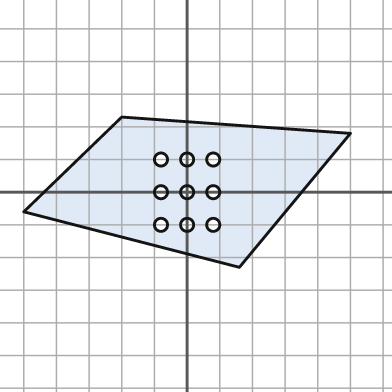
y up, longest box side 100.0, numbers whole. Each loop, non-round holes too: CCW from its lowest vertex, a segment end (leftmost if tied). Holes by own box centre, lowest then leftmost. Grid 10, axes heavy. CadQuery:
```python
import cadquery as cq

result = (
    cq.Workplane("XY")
    .moveTo(16.0, -23.0)
    .lineTo(50.0, 18.0)
    .lineTo(-20.0, 23.0)
    .lineTo(-50.0, -6.0)
    .close()
    .moveTo(-8.0, -10.0)
    .circle(2.0)
    .moveTo(0.0, -10.0)
    .circle(2.0)
    .moveTo(8.0, -10.0)
    .circle(2.0)
    .moveTo(-8.0, 0.0)
    .circle(2.0)
    .moveTo(0.0, 0.0)
    .circle(2.0)
    .moveTo(8.0, 0.0)
    .circle(2.0)
    .moveTo(-8.0, 10.0)
    .circle(2.0)
    .moveTo(0.0, 10.0)
    .circle(2.0)
    .moveTo(8.0, 10.0)
    .circle(2.0)
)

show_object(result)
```